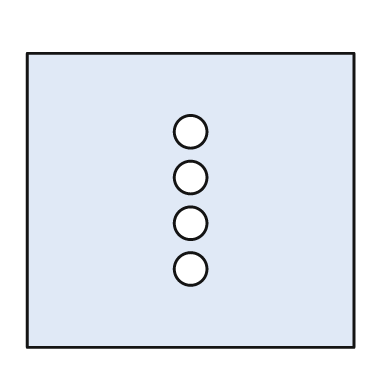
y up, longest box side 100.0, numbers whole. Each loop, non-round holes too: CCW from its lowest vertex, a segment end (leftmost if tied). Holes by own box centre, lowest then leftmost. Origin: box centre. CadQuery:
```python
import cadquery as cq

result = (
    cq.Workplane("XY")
    .moveTo(-50.0, -45.0)
    .lineTo(50.0, -45.0)
    .lineTo(50.0, 45.0)
    .lineTo(-50.0, 45.0)
    .close()
    .moveTo(0.0, -21.0)
    .circle(5.0)
    .moveTo(0.0, -7.0)
    .circle(5.0)
    .moveTo(0.0, 7.0)
    .circle(5.0)
    .moveTo(0.0, 21.0)
    .circle(5.0)
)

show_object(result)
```